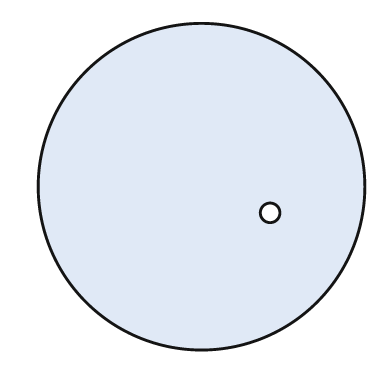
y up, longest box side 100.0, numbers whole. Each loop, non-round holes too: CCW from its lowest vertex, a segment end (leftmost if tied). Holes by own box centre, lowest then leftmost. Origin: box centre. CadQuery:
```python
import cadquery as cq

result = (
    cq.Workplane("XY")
    .moveTo(0.0, 0.0)
    .circle(50.0)
    .moveTo(21.0, -8.0)
    .circle(3.0)
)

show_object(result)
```